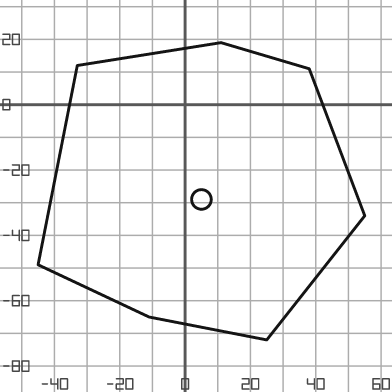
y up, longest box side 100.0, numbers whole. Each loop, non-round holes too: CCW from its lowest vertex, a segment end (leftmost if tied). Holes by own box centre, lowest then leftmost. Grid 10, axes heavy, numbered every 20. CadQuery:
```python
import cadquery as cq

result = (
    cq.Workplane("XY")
    .moveTo(25.0, -72.0)
    .lineTo(55.0, -34.0)
    .lineTo(38.0, 11.0)
    .lineTo(11.0, 19.0)
    .lineTo(-33.0, 12.0)
    .lineTo(-45.0, -49.0)
    .lineTo(-11.0, -65.0)
    .close()
    .moveTo(5.0, -29.0)
    .circle(3.0)
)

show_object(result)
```